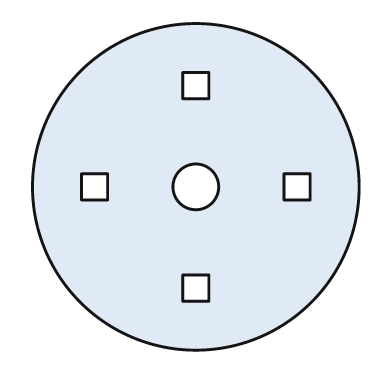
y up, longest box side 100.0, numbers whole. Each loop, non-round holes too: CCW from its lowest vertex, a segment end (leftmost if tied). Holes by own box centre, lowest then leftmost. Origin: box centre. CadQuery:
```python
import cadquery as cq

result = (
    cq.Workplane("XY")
    .moveTo(0.0, 0.0)
    .circle(50.0)
    .moveTo(-4.0, -35.0)
    .lineTo(4.0, -35.0)
    .lineTo(4.0, -27.0)
    .lineTo(-4.0, -27.0)
    .close()
    .moveTo(-35.0, -4.0)
    .lineTo(-27.0, -4.0)
    .lineTo(-27.0, 4.0)
    .lineTo(-35.0, 4.0)
    .close()
    .moveTo(0.0, 0.0)
    .circle(7.0)
    .moveTo(27.0, -4.0)
    .lineTo(35.0, -4.0)
    .lineTo(35.0, 4.0)
    .lineTo(27.0, 4.0)
    .close()
    .moveTo(-4.0, 27.0)
    .lineTo(4.0, 27.0)
    .lineTo(4.0, 35.0)
    .lineTo(-4.0, 35.0)
    .close()
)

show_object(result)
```